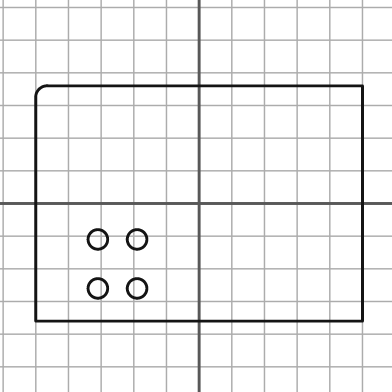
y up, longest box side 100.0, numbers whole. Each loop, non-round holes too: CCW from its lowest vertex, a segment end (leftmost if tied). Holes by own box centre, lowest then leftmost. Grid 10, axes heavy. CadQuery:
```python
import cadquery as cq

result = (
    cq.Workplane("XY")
    .moveTo(-50.0, -36.0)
    .lineTo(50.0, -36.0)
    .lineTo(50.0, 36.0)
    .lineTo(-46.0, 36.0)
    .threePointArc((-49.0, 35.0), (-50.0, 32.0))
    .close()
    .moveTo(-31.0, -26.0)
    .circle(3.0)
    .moveTo(-19.0, -26.0)
    .circle(3.0)
    .moveTo(-31.0, -11.0)
    .circle(3.0)
    .moveTo(-19.0, -11.0)
    .circle(3.0)
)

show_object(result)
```